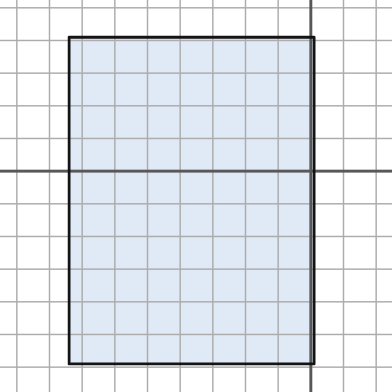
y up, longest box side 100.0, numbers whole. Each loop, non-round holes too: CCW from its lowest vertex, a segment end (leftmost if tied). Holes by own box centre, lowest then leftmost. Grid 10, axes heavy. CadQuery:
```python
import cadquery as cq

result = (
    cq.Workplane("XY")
    .moveTo(-74.0, -59.0)
    .lineTo(1.0, -59.0)
    .lineTo(1.0, 41.0)
    .lineTo(-74.0, 41.0)
    .close()
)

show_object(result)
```